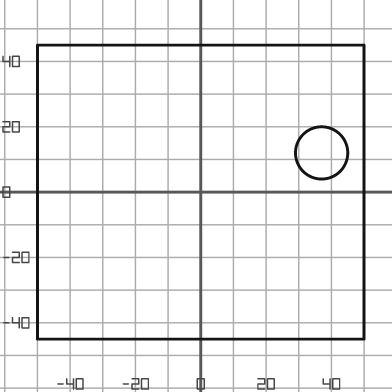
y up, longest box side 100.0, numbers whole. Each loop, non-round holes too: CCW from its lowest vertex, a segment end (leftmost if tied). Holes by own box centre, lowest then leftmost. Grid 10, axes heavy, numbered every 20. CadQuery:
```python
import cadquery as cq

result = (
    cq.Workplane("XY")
    .moveTo(-50.0, -45.0)
    .lineTo(50.0, -45.0)
    .lineTo(50.0, 45.0)
    .lineTo(-50.0, 45.0)
    .close()
    .moveTo(37.0, 12.0)
    .circle(8.0)
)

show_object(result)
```